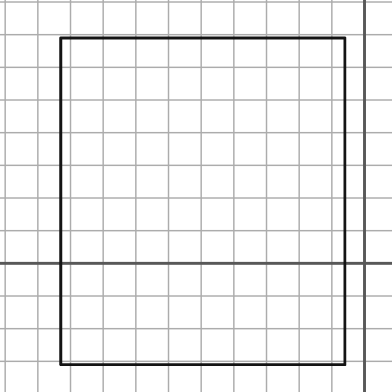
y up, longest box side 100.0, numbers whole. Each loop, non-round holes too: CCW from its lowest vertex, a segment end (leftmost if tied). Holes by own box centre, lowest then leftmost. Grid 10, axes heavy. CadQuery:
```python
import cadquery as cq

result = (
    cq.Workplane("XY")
    .moveTo(-93.0, -31.0)
    .lineTo(-6.0, -31.0)
    .lineTo(-6.0, 69.0)
    .lineTo(-93.0, 69.0)
    .close()
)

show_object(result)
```